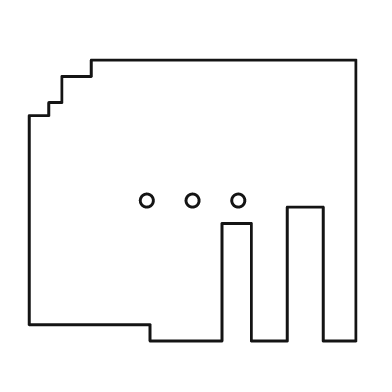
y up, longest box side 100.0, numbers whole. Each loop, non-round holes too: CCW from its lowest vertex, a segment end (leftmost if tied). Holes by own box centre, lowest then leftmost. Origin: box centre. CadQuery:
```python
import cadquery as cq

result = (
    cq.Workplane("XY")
    .moveTo(-13.0, -43.0)
    .lineTo(9.0, -43.0)
    .lineTo(9.0, -7.0)
    .lineTo(18.0, -7.0)
    .lineTo(18.0, -43.0)
    .lineTo(29.0, -43.0)
    .lineTo(29.0, -2.0)
    .lineTo(40.0, -2.0)
    .lineTo(40.0, -43.0)
    .lineTo(50.0, -43.0)
    .lineTo(50.0, 43.0)
    .lineTo(-31.0, 43.0)
    .lineTo(-31.0, 38.0)
    .lineTo(-40.0, 38.0)
    .lineTo(-40.0, 30.0)
    .lineTo(-44.0, 30.0)
    .lineTo(-44.0, 26.0)
    .lineTo(-50.0, 26.0)
    .lineTo(-50.0, -38.0)
    .lineTo(-13.0, -38.0)
    .close()
    .moveTo(-14.0, 0.0)
    .circle(2.0)
    .moveTo(0.0, 0.0)
    .circle(2.0)
    .moveTo(14.0, 0.0)
    .circle(2.0)
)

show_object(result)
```